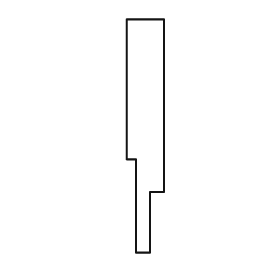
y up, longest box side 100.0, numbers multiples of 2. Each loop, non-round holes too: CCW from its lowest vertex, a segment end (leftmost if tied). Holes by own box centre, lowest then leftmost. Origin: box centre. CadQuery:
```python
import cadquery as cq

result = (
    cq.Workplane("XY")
    .moveTo(-4.0, -50.0)
    .lineTo(2.0, -50.0)
    .lineTo(2.0, -24.0)
    .lineTo(8.0, -24.0)
    .lineTo(8.0, 50.0)
    .lineTo(-8.0, 50.0)
    .lineTo(-8.0, -10.0)
    .lineTo(-4.0, -10.0)
    .close()
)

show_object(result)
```